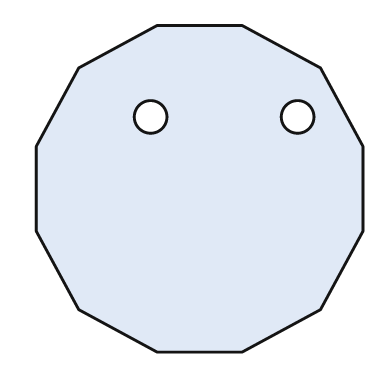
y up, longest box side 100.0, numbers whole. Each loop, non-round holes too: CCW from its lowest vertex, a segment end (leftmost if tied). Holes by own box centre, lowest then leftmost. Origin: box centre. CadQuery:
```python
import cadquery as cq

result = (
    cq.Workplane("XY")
    .moveTo(-13.0, -50.0)
    .lineTo(13.0, -50.0)
    .lineTo(37.0, -37.0)
    .lineTo(50.0, -13.0)
    .lineTo(50.0, 13.0)
    .lineTo(37.0, 37.0)
    .lineTo(13.0, 50.0)
    .lineTo(-13.0, 50.0)
    .lineTo(-37.0, 37.0)
    .lineTo(-50.0, 13.0)
    .lineTo(-50.0, -13.0)
    .lineTo(-37.0, -37.0)
    .close()
    .moveTo(-15.0, 22.0)
    .circle(5.0)
    .moveTo(30.0, 22.0)
    .circle(5.0)
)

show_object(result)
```